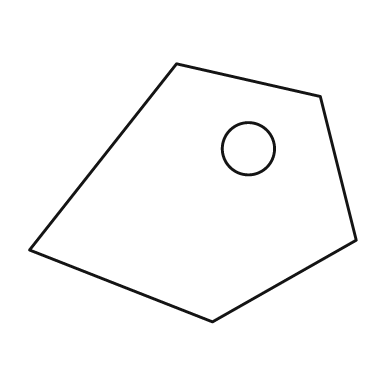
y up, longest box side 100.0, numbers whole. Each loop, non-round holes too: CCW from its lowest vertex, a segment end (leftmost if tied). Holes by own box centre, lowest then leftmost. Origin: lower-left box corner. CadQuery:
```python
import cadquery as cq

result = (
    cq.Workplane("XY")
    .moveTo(56.0, 0.0)
    .lineTo(100.0, 25.0)
    .lineTo(89.0, 69.0)
    .lineTo(45.0, 79.0)
    .lineTo(0.0, 22.0)
    .close()
    .moveTo(67.0, 53.0)
    .circle(8.0)
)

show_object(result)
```